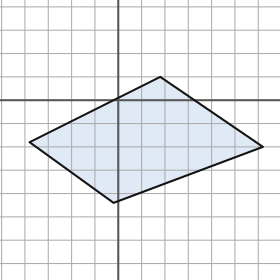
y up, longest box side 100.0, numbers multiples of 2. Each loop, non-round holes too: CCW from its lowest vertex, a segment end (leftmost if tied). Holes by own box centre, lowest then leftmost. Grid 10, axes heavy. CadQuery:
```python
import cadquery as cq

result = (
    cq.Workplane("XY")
    .moveTo(-2.0, -44.0)
    .lineTo(62.0, -20.0)
    .lineTo(18.0, 10.0)
    .lineTo(-38.0, -18.0)
    .close()
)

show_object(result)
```